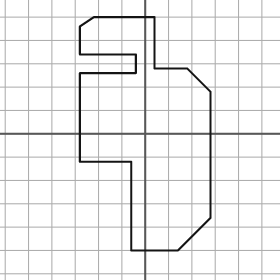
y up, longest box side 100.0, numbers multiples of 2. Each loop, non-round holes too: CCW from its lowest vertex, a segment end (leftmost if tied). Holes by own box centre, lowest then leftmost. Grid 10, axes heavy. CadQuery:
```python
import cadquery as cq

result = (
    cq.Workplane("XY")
    .moveTo(-6.0, -50.0)
    .lineTo(14.0, -50.0)
    .lineTo(28.0, -36.0)
    .lineTo(28.0, 18.0)
    .lineTo(18.0, 28.0)
    .lineTo(4.0, 28.0)
    .lineTo(4.0, 50.0)
    .lineTo(-22.0, 50.0)
    .lineTo(-28.0, 46.0)
    .lineTo(-28.0, 34.0)
    .lineTo(-4.0, 34.0)
    .lineTo(-4.0, 26.0)
    .lineTo(-28.0, 26.0)
    .lineTo(-28.0, -12.0)
    .lineTo(-6.0, -12.0)
    .close()
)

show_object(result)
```